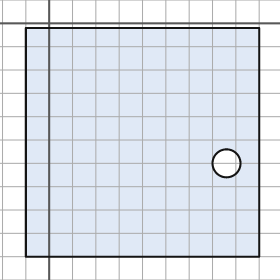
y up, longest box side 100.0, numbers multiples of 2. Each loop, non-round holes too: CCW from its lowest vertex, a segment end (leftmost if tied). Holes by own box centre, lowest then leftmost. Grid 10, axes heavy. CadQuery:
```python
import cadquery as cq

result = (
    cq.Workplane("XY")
    .moveTo(-10.0, -100.0)
    .lineTo(90.0, -100.0)
    .lineTo(90.0, -2.0)
    .lineTo(-10.0, -2.0)
    .close()
    .moveTo(76.0, -60.0)
    .circle(6.0)
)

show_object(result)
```